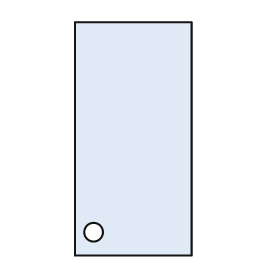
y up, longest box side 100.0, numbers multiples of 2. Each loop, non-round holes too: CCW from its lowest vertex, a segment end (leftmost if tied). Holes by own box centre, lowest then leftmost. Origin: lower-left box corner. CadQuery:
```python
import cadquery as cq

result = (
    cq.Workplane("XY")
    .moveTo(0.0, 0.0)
    .lineTo(50.0, 0.0)
    .lineTo(50.0, 100.0)
    .lineTo(0.0, 100.0)
    .close()
    .moveTo(8.0, 10.0)
    .circle(4.0)
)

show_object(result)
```